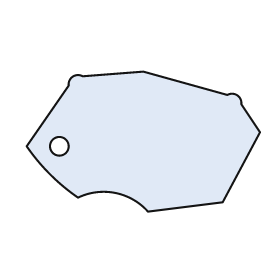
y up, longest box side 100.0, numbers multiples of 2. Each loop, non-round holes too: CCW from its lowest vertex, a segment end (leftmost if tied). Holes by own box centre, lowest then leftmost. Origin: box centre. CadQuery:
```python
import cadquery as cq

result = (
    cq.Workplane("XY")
    .moveTo(2.0, -30.0)
    .lineTo(34.0, -26.0)
    .lineTo(50.0, 4.0)
    .lineTo(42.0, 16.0)
    .threePointArc((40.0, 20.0), (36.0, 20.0))
    .lineTo(0.0, 30.0)
    .lineTo(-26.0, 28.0)
    .threePointArc((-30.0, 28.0), (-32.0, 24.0))
    .lineTo(-50.0, -2.0)
    .threePointArc((-40.0, -14.0), (-28.0, -24.0))
    .threePointArc((-12.0, -22.0), (2.0, -30.0))
    .close()
    .moveTo(-36.0, -2.0)
    .circle(4.0)
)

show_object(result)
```